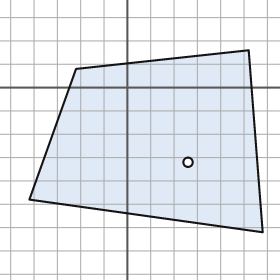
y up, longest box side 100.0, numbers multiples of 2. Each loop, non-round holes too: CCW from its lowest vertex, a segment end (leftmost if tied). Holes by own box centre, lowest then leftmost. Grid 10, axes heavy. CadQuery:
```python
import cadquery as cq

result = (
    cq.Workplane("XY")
    .moveTo(58.0, -62.0)
    .lineTo(52.0, 16.0)
    .lineTo(-22.0, 8.0)
    .lineTo(-42.0, -48.0)
    .close()
    .moveTo(26.0, -32.0)
    .circle(2.0)
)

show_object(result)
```